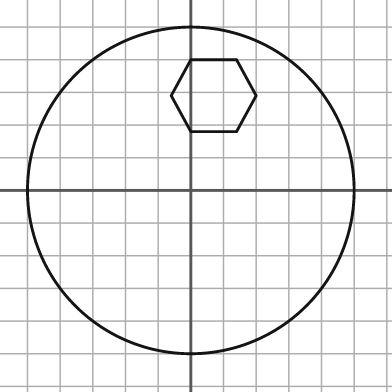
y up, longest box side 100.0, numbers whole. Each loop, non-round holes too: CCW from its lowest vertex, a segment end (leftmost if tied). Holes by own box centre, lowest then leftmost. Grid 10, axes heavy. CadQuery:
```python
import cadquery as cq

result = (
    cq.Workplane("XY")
    .moveTo(0.0, 0.0)
    .circle(50.0)
    .moveTo(0.0, 18.0)
    .lineTo(14.0, 18.0)
    .lineTo(20.0, 29.0)
    .lineTo(14.0, 40.0)
    .lineTo(0.0, 40.0)
    .lineTo(-6.0, 29.0)
    .close()
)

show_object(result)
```